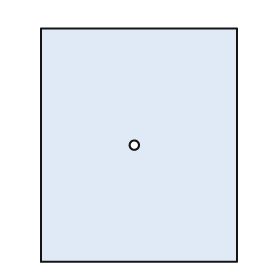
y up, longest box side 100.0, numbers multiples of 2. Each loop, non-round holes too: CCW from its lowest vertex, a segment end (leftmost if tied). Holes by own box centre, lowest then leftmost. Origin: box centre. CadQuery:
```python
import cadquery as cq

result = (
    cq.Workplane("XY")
    .moveTo(-42.0, -50.0)
    .lineTo(42.0, -50.0)
    .lineTo(42.0, 50.0)
    .lineTo(-42.0, 50.0)
    .close()
    .moveTo(-2.0, 0.0)
    .circle(2.0)
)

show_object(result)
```